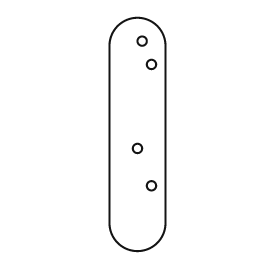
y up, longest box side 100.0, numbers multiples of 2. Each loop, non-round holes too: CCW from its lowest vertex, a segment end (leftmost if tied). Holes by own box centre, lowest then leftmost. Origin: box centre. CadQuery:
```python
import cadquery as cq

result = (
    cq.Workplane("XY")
    .moveTo(-12.0, -38.0)
    .threePointArc((0.0, -50.0), (12.0, -38.0))
    .lineTo(12.0, 38.0)
    .threePointArc((0.0, 50.0), (-12.0, 38.0))
    .close()
    .moveTo(6.0, -22.0)
    .circle(2.0)
    .moveTo(0.0, -6.0)
    .circle(2.0)
    .moveTo(6.0, 30.0)
    .circle(2.0)
    .moveTo(2.0, 40.0)
    .circle(2.0)
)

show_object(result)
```